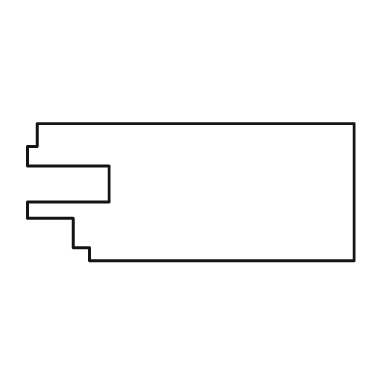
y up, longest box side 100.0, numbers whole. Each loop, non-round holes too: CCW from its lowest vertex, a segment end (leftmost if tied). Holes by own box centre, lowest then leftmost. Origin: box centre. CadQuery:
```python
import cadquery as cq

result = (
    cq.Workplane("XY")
    .moveTo(-31.0, -21.0)
    .lineTo(50.0, -21.0)
    .lineTo(50.0, 21.0)
    .lineTo(-47.0, 21.0)
    .lineTo(-47.0, 14.0)
    .lineTo(-50.0, 14.0)
    .lineTo(-50.0, 8.0)
    .lineTo(-25.0, 8.0)
    .lineTo(-25.0, -3.0)
    .lineTo(-50.0, -3.0)
    .lineTo(-50.0, -8.0)
    .lineTo(-36.0, -8.0)
    .lineTo(-36.0, -17.0)
    .lineTo(-31.0, -17.0)
    .close()
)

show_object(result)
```